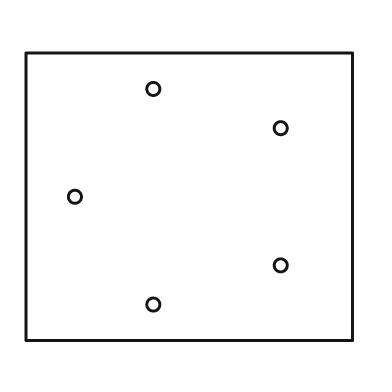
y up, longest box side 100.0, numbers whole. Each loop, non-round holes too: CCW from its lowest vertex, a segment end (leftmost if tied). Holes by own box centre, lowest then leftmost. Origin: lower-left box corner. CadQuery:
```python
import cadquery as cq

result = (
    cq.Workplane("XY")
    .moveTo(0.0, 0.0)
    .lineTo(100.0, 0.0)
    .lineTo(100.0, 88.0)
    .lineTo(0.0, 88.0)
    .close()
    .moveTo(39.0, 11.0)
    .circle(2.0)
    .moveTo(78.0, 23.0)
    .circle(2.0)
    .moveTo(15.0, 44.0)
    .circle(2.0)
    .moveTo(78.0, 65.0)
    .circle(2.0)
    .moveTo(39.0, 77.0)
    .circle(2.0)
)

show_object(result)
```